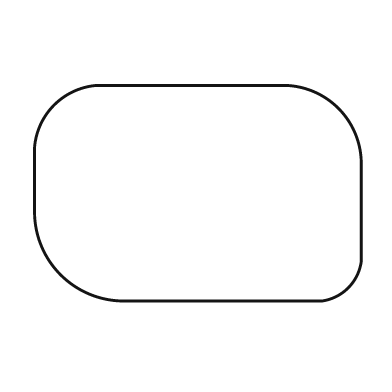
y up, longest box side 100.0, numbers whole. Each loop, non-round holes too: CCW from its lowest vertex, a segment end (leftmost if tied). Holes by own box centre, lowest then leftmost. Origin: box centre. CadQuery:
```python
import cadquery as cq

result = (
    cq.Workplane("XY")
    .moveTo(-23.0, -33.0)
    .lineTo(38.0, -33.0)
    .threePointArc((46.0, -29.0), (50.0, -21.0))
    .lineTo(50.0, 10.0)
    .threePointArc((43.0, 26.0), (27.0, 33.0))
    .lineTo(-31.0, 33.0)
    .threePointArc((-44.0, 27.0), (-50.0, 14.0))
    .lineTo(-50.0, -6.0)
    .threePointArc((-42.0, -25.0), (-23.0, -33.0))
    .close()
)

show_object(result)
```